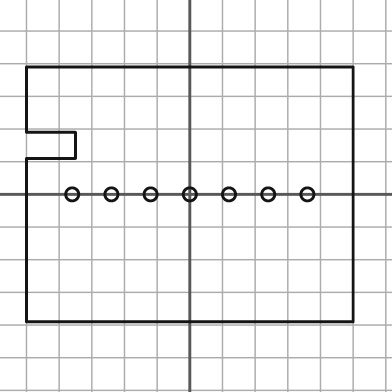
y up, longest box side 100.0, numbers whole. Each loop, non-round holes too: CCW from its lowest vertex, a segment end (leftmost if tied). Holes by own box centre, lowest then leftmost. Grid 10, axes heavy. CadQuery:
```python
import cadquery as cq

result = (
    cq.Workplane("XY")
    .moveTo(-50.0, -39.0)
    .lineTo(50.0, -39.0)
    .lineTo(50.0, 39.0)
    .lineTo(-50.0, 39.0)
    .lineTo(-50.0, 19.0)
    .lineTo(-35.0, 19.0)
    .lineTo(-35.0, 11.0)
    .lineTo(-50.0, 11.0)
    .close()
    .moveTo(-36.0, 0.0)
    .circle(2.0)
    .moveTo(-24.0, 0.0)
    .circle(2.0)
    .moveTo(-12.0, 0.0)
    .circle(2.0)
    .moveTo(0.0, 0.0)
    .circle(2.0)
    .moveTo(12.0, 0.0)
    .circle(2.0)
    .moveTo(24.0, 0.0)
    .circle(2.0)
    .moveTo(36.0, 0.0)
    .circle(2.0)
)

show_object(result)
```